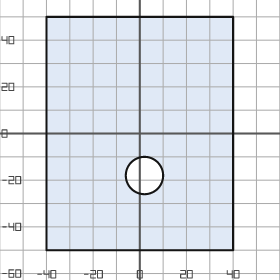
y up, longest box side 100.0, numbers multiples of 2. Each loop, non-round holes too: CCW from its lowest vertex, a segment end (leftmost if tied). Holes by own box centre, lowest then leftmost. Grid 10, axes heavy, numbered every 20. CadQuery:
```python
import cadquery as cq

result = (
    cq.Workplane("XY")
    .moveTo(-40.0, -50.0)
    .lineTo(40.0, -50.0)
    .lineTo(40.0, 50.0)
    .lineTo(-40.0, 50.0)
    .close()
    .moveTo(2.0, -18.0)
    .circle(8.0)
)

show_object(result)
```